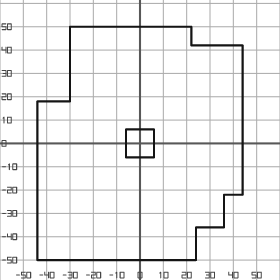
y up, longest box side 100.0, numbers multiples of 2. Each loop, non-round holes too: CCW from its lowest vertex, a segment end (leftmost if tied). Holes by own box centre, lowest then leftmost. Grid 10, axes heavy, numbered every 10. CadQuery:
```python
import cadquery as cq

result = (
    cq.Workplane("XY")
    .moveTo(-44.0, -50.0)
    .lineTo(24.0, -50.0)
    .lineTo(24.0, -36.0)
    .lineTo(36.0, -36.0)
    .lineTo(36.0, -22.0)
    .lineTo(44.0, -22.0)
    .lineTo(44.0, 42.0)
    .lineTo(22.0, 42.0)
    .lineTo(22.0, 50.0)
    .lineTo(-30.0, 50.0)
    .lineTo(-30.0, 18.0)
    .lineTo(-44.0, 18.0)
    .close()
    .moveTo(-6.0, -6.0)
    .lineTo(6.0, -6.0)
    .lineTo(6.0, 6.0)
    .lineTo(-6.0, 6.0)
    .close()
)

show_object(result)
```